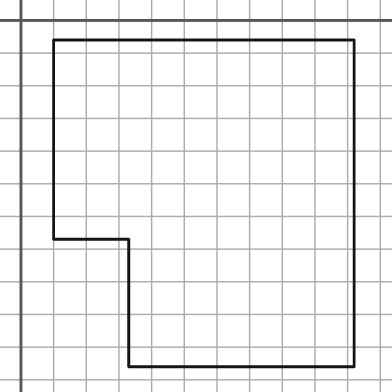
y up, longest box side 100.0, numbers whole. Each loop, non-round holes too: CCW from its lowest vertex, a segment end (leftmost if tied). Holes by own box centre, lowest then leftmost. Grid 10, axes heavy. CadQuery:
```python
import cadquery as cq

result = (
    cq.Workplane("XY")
    .moveTo(33.0, -106.0)
    .lineTo(102.0, -106.0)
    .lineTo(102.0, -6.0)
    .lineTo(10.0, -6.0)
    .lineTo(10.0, -67.0)
    .lineTo(33.0, -67.0)
    .close()
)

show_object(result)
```